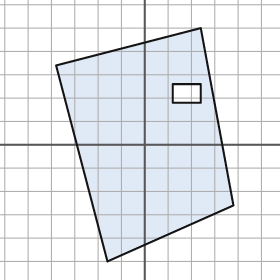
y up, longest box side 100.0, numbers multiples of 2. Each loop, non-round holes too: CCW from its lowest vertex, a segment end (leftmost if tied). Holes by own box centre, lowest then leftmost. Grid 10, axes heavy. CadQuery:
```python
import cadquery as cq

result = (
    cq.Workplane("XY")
    .moveTo(-16.0, -50.0)
    .lineTo(38.0, -26.0)
    .lineTo(24.0, 50.0)
    .lineTo(-38.0, 34.0)
    .close()
    .moveTo(12.0, 18.0)
    .lineTo(24.0, 18.0)
    .lineTo(24.0, 26.0)
    .lineTo(12.0, 26.0)
    .close()
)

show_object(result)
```